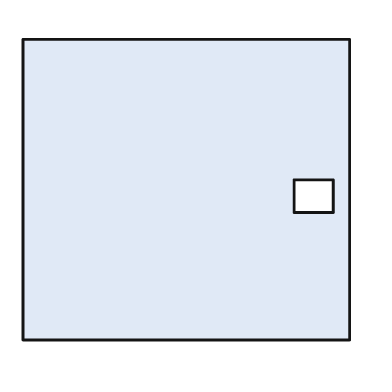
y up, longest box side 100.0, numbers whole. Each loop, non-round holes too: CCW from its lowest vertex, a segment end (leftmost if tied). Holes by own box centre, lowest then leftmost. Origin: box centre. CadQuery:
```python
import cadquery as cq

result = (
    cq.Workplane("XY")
    .moveTo(-50.0, -46.0)
    .lineTo(50.0, -46.0)
    .lineTo(50.0, 46.0)
    .lineTo(-50.0, 46.0)
    .close()
    .moveTo(33.0, -7.0)
    .lineTo(45.0, -7.0)
    .lineTo(45.0, 3.0)
    .lineTo(33.0, 3.0)
    .close()
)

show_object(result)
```